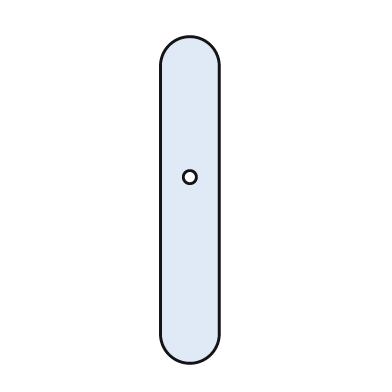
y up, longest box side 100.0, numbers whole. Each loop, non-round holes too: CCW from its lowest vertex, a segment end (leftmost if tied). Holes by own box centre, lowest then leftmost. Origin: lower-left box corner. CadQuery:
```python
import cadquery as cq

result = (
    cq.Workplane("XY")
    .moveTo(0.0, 9.0)
    .threePointArc((9.0, 0.0), (18.0, 9.0))
    .lineTo(18.0, 91.0)
    .threePointArc((9.0, 100.0), (0.0, 91.0))
    .close()
    .moveTo(9.0, 57.0)
    .circle(2.0)
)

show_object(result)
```